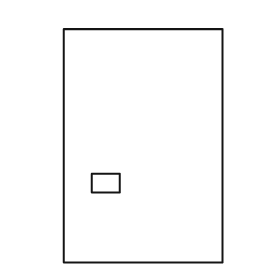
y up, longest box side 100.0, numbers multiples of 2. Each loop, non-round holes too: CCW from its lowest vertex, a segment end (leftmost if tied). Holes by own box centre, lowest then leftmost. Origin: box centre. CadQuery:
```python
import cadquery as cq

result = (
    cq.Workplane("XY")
    .moveTo(-34.0, -50.0)
    .lineTo(34.0, -50.0)
    .lineTo(34.0, 50.0)
    .lineTo(-34.0, 50.0)
    .close()
    .moveTo(-22.0, -20.0)
    .lineTo(-10.0, -20.0)
    .lineTo(-10.0, -12.0)
    .lineTo(-22.0, -12.0)
    .close()
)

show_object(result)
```